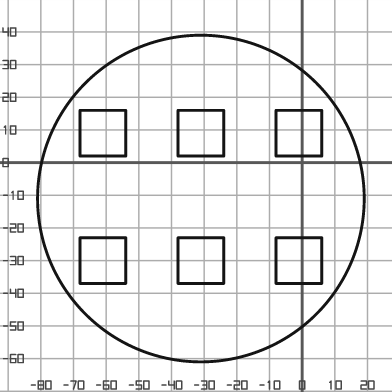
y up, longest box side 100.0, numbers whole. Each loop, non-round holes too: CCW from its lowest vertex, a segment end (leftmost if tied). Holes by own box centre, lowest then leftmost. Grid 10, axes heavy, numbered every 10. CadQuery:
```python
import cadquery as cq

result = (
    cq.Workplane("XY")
    .moveTo(-31.0, -11.0)
    .circle(50.0)
    .moveTo(-68.0, -37.0)
    .lineTo(-54.0, -37.0)
    .lineTo(-54.0, -23.0)
    .lineTo(-68.0, -23.0)
    .close()
    .moveTo(-38.0, -37.0)
    .lineTo(-24.0, -37.0)
    .lineTo(-24.0, -23.0)
    .lineTo(-38.0, -23.0)
    .close()
    .moveTo(-8.0, -37.0)
    .lineTo(6.0, -37.0)
    .lineTo(6.0, -23.0)
    .lineTo(-8.0, -23.0)
    .close()
    .moveTo(-68.0, 2.0)
    .lineTo(-54.0, 2.0)
    .lineTo(-54.0, 16.0)
    .lineTo(-68.0, 16.0)
    .close()
    .moveTo(-38.0, 2.0)
    .lineTo(-24.0, 2.0)
    .lineTo(-24.0, 16.0)
    .lineTo(-38.0, 16.0)
    .close()
    .moveTo(-8.0, 2.0)
    .lineTo(6.0, 2.0)
    .lineTo(6.0, 16.0)
    .lineTo(-8.0, 16.0)
    .close()
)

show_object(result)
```